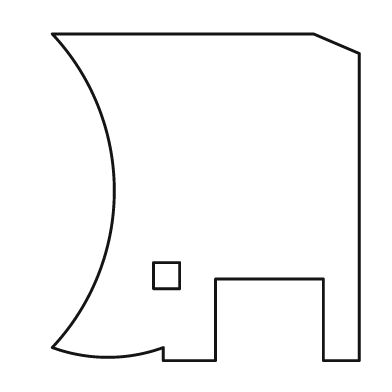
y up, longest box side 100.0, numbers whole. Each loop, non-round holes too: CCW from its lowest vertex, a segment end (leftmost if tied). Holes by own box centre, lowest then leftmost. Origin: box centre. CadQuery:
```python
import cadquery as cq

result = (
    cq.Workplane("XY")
    .moveTo(-13.0, -50.0)
    .lineTo(3.0, -50.0)
    .lineTo(3.0, -25.0)
    .lineTo(36.0, -25.0)
    .lineTo(36.0, -50.0)
    .lineTo(47.0, -50.0)
    .lineTo(47.0, 44.0)
    .lineTo(33.0, 50.0)
    .lineTo(-47.0, 50.0)
    .threePointArc((-28.0, 2.0), (-47.0, -46.0))
    .threePointArc((-30.0, -49.0), (-13.0, -46.0))
    .close()
    .moveTo(-16.0, -28.0)
    .lineTo(-8.0, -28.0)
    .lineTo(-8.0, -20.0)
    .lineTo(-16.0, -20.0)
    .close()
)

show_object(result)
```